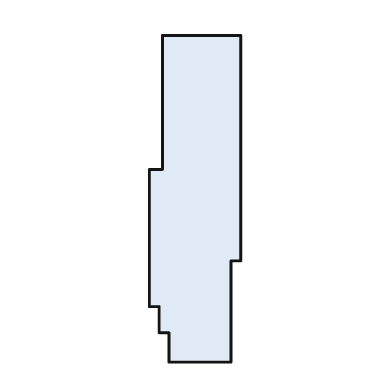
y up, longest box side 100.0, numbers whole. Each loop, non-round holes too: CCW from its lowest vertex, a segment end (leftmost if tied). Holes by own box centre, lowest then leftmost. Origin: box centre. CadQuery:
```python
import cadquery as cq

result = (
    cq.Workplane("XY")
    .moveTo(-8.0, -50.0)
    .lineTo(11.0, -50.0)
    .lineTo(11.0, -19.0)
    .lineTo(14.0, -19.0)
    .lineTo(14.0, 50.0)
    .lineTo(-10.0, 50.0)
    .lineTo(-10.0, 9.0)
    .lineTo(-14.0, 9.0)
    .lineTo(-14.0, -33.0)
    .lineTo(-11.0, -33.0)
    .lineTo(-11.0, -41.0)
    .lineTo(-8.0, -41.0)
    .close()
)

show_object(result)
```